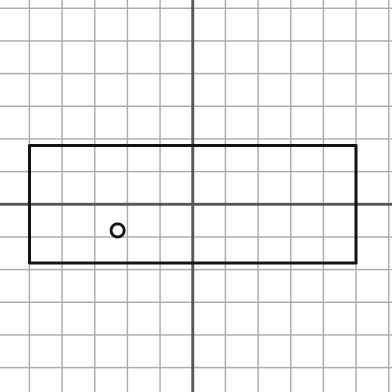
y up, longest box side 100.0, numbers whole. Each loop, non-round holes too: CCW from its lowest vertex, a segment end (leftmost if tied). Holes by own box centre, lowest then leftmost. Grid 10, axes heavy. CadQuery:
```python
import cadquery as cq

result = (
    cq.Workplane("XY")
    .moveTo(-50.0, -18.0)
    .lineTo(50.0, -18.0)
    .lineTo(50.0, 18.0)
    .lineTo(-50.0, 18.0)
    .close()
    .moveTo(-23.0, -8.0)
    .circle(2.0)
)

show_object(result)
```